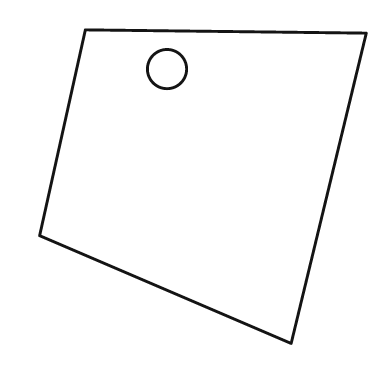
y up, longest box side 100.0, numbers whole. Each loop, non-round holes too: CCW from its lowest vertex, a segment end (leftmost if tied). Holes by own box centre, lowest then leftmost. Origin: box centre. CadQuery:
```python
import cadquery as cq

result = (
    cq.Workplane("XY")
    .moveTo(27.0, -48.0)
    .lineTo(50.0, 47.0)
    .lineTo(-36.0, 48.0)
    .lineTo(-50.0, -15.0)
    .close()
    .moveTo(-11.0, 36.0)
    .circle(6.0)
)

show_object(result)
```